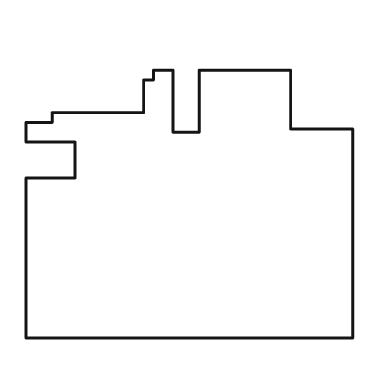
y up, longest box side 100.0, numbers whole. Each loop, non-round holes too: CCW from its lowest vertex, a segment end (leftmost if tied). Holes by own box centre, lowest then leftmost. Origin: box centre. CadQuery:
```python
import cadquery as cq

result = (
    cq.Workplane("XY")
    .moveTo(-50.0, -41.0)
    .lineTo(50.0, -41.0)
    .lineTo(50.0, 23.0)
    .lineTo(31.0, 23.0)
    .lineTo(31.0, 41.0)
    .lineTo(3.0, 41.0)
    .lineTo(3.0, 22.0)
    .lineTo(-5.0, 22.0)
    .lineTo(-5.0, 41.0)
    .lineTo(-11.0, 41.0)
    .lineTo(-11.0, 38.0)
    .lineTo(-14.0, 38.0)
    .lineTo(-14.0, 28.0)
    .lineTo(-42.0, 28.0)
    .lineTo(-42.0, 25.0)
    .lineTo(-50.0, 25.0)
    .lineTo(-50.0, 19.0)
    .lineTo(-35.0, 19.0)
    .lineTo(-35.0, 8.0)
    .lineTo(-50.0, 8.0)
    .close()
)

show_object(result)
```